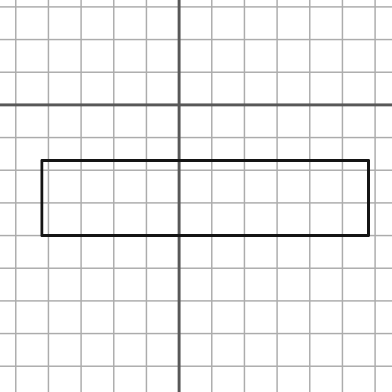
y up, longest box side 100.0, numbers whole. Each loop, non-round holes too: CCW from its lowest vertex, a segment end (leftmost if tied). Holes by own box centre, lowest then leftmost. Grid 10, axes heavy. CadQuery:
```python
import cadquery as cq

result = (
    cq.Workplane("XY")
    .moveTo(-42.0, -40.0)
    .lineTo(58.0, -40.0)
    .lineTo(58.0, -17.0)
    .lineTo(-42.0, -17.0)
    .close()
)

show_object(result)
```